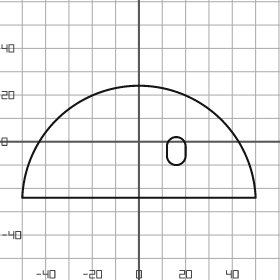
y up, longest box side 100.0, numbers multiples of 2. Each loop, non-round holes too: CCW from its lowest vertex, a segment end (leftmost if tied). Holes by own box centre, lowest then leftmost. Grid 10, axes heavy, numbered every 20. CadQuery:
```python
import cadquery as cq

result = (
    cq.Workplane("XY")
    .moveTo(-50.0, -24.0)
    .lineTo(50.0, -24.0)
    .threePointArc((0.0, 24.0), (-50.0, -24.0))
    .close()
    .moveTo(12.0, -6.0)
    .threePointArc((16.0, -10.0), (20.0, -6.0))
    .lineTo(20.0, -2.0)
    .threePointArc((16.0, 2.0), (12.0, -2.0))
    .close()
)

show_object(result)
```